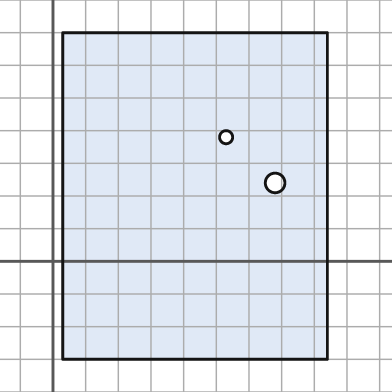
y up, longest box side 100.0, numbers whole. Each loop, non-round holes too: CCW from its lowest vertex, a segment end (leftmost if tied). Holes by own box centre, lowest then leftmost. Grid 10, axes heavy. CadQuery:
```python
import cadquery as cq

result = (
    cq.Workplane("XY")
    .moveTo(3.0, -30.0)
    .lineTo(84.0, -30.0)
    .lineTo(84.0, 70.0)
    .lineTo(3.0, 70.0)
    .close()
    .moveTo(68.0, 24.0)
    .circle(3.0)
    .moveTo(53.0, 38.0)
    .circle(2.0)
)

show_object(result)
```